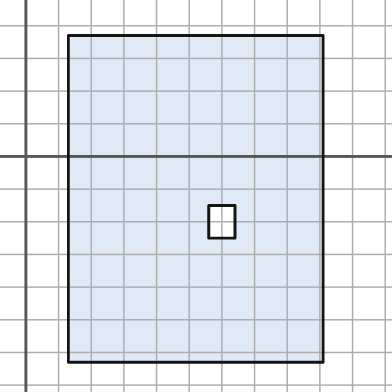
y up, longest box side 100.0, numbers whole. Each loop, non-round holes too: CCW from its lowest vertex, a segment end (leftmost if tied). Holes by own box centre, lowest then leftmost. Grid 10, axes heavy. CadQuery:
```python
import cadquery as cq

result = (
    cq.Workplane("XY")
    .moveTo(13.0, -63.0)
    .lineTo(91.0, -63.0)
    .lineTo(91.0, 37.0)
    .lineTo(13.0, 37.0)
    .close()
    .moveTo(56.0, -25.0)
    .lineTo(64.0, -25.0)
    .lineTo(64.0, -15.0)
    .lineTo(56.0, -15.0)
    .close()
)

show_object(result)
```